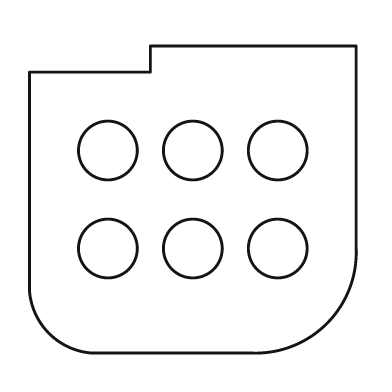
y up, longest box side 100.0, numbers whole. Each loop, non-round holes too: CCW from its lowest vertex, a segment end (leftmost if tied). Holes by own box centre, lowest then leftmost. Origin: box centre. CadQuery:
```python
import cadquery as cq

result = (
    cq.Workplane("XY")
    .moveTo(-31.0, -47.0)
    .lineTo(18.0, -47.0)
    .threePointArc((41.0, -38.0), (50.0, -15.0))
    .lineTo(50.0, 47.0)
    .lineTo(-13.0, 47.0)
    .lineTo(-13.0, 39.0)
    .lineTo(-50.0, 39.0)
    .lineTo(-50.0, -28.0)
    .threePointArc((-44.0, -41.0), (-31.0, -47.0))
    .close()
    .moveTo(-26.0, -15.0)
    .circle(9.0)
    .moveTo(0.0, -15.0)
    .circle(9.0)
    .moveTo(26.0, -15.0)
    .circle(9.0)
    .moveTo(-26.0, 15.0)
    .circle(9.0)
    .moveTo(0.0, 15.0)
    .circle(9.0)
    .moveTo(26.0, 15.0)
    .circle(9.0)
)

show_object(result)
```